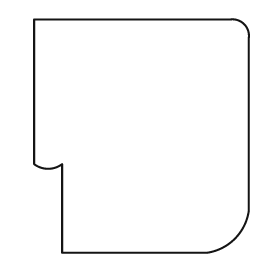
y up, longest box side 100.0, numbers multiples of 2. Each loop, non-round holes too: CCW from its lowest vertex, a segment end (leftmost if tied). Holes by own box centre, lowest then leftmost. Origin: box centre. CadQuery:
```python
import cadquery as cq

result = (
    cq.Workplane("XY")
    .moveTo(-34.0, -50.0)
    .lineTo(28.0, -50.0)
    .threePointArc((40.0, -44.0), (46.0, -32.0))
    .lineTo(46.0, 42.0)
    .threePointArc((44.0, 48.0), (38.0, 50.0))
    .lineTo(-46.0, 50.0)
    .lineTo(-46.0, -12.0)
    .threePointArc((-40.0, -14.0), (-34.0, -12.0))
    .close()
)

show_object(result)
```